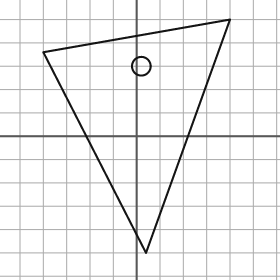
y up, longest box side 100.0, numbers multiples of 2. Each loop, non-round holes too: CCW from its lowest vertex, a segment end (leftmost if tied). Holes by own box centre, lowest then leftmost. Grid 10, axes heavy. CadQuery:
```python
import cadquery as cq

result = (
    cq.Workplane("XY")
    .moveTo(4.0, -50.0)
    .lineTo(40.0, 50.0)
    .lineTo(-40.0, 36.0)
    .close()
    .moveTo(2.0, 30.0)
    .circle(4.0)
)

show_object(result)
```